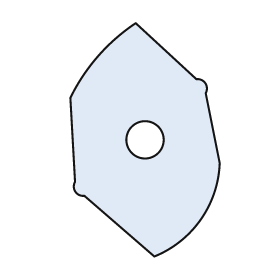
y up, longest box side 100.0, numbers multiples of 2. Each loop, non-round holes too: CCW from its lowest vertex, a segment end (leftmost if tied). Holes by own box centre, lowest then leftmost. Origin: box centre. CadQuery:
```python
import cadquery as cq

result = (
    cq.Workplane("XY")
    .moveTo(4.0, -50.0)
    .threePointArc((24.0, -34.0), (32.0, -10.0))
    .lineTo(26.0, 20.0)
    .threePointArc((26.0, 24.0), (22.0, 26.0))
    .lineTo(-4.0, 50.0)
    .threePointArc((-20.0, 36.0), (-32.0, 18.0))
    .lineTo(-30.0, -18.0)
    .threePointArc((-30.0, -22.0), (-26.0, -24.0))
    .close()
    .moveTo(0.0, 0.0)
    .circle(8.0)
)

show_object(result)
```